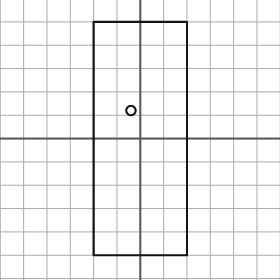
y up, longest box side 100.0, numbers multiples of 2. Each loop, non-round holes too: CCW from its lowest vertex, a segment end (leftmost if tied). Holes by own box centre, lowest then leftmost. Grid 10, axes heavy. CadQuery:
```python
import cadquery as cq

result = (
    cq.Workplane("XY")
    .moveTo(-20.0, -50.0)
    .lineTo(20.0, -50.0)
    .lineTo(20.0, 50.0)
    .lineTo(-20.0, 50.0)
    .close()
    .moveTo(-4.0, 12.0)
    .circle(2.0)
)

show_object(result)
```